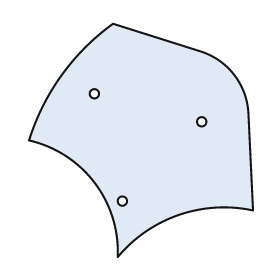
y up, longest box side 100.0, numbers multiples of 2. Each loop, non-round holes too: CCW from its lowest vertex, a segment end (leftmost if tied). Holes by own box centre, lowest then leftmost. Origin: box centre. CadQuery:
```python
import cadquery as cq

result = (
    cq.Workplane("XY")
    .moveTo(-10.0, -50.0)
    .threePointArc((16.0, -32.0), (48.0, -30.0))
    .lineTo(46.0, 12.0)
    .threePointArc((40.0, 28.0), (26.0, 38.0))
    .lineTo(-12.0, 50.0)
    .threePointArc((-34.0, 28.0), (-48.0, 0.0))
    .threePointArc((-20.0, -18.0), (-10.0, -50.0))
    .close()
    .moveTo(-8.0, -26.0)
    .circle(2.0)
    .moveTo(26.0, 8.0)
    .circle(2.0)
    .moveTo(-20.0, 20.0)
    .circle(2.0)
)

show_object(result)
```